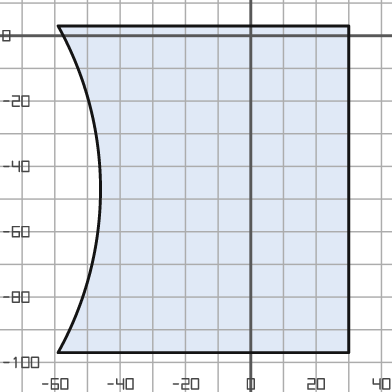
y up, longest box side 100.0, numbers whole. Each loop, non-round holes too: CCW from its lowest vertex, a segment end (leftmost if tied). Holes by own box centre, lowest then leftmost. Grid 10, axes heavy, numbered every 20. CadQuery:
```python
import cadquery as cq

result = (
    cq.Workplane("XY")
    .moveTo(-59.0, -97.0)
    .lineTo(30.0, -97.0)
    .lineTo(30.0, 3.0)
    .lineTo(-59.0, 3.0)
    .threePointArc((-46.0, -47.0), (-59.0, -97.0))
    .close()
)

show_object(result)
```